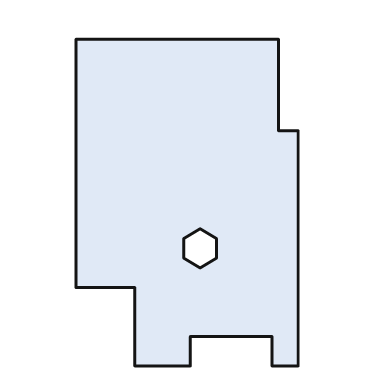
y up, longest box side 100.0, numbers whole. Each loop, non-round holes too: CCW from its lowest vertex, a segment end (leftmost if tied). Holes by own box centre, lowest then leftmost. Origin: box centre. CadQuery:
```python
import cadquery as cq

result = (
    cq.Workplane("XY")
    .moveTo(-16.0, -50.0)
    .lineTo(1.0, -50.0)
    .lineTo(1.0, -41.0)
    .lineTo(26.0, -41.0)
    .lineTo(26.0, -50.0)
    .lineTo(34.0, -50.0)
    .lineTo(34.0, 22.0)
    .lineTo(28.0, 22.0)
    .lineTo(28.0, 50.0)
    .lineTo(-34.0, 50.0)
    .lineTo(-34.0, -26.0)
    .lineTo(-16.0, -26.0)
    .close()
    .moveTo(4.0, -20.0)
    .lineTo(9.0, -17.0)
    .lineTo(9.0, -11.0)
    .lineTo(4.0, -8.0)
    .lineTo(-1.0, -11.0)
    .lineTo(-1.0, -17.0)
    .close()
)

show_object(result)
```